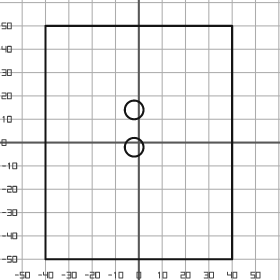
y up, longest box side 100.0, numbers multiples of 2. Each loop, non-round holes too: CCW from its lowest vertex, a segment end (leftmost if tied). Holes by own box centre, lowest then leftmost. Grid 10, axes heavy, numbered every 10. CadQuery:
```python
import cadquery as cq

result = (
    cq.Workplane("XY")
    .moveTo(-40.0, -50.0)
    .lineTo(40.0, -50.0)
    .lineTo(40.0, 50.0)
    .lineTo(-40.0, 50.0)
    .close()
    .moveTo(-2.0, -2.0)
    .circle(4.0)
    .moveTo(-2.0, 14.0)
    .circle(4.0)
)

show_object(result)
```